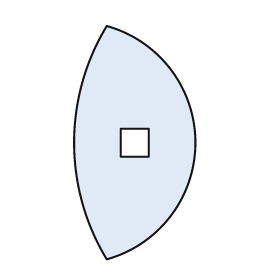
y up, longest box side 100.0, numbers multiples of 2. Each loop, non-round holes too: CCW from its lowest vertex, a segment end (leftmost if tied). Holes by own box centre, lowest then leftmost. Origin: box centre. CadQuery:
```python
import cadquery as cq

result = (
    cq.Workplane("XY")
    .moveTo(-12.0, -50.0)
    .threePointArc((26.0, 0.0), (-12.0, 50.0))
    .threePointArc((-26.0, 0.0), (-12.0, -50.0))
    .close()
    .moveTo(-6.0, -6.0)
    .lineTo(6.0, -6.0)
    .lineTo(6.0, 6.0)
    .lineTo(-6.0, 6.0)
    .close()
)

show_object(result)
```